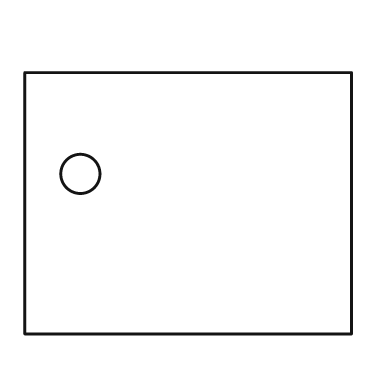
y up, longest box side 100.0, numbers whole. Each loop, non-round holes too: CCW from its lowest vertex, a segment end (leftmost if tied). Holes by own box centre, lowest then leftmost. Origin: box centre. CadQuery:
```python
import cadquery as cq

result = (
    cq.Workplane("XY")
    .moveTo(-50.0, -40.0)
    .lineTo(50.0, -40.0)
    .lineTo(50.0, 40.0)
    .lineTo(-50.0, 40.0)
    .close()
    .moveTo(-33.0, 9.0)
    .circle(6.0)
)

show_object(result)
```